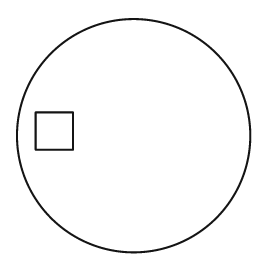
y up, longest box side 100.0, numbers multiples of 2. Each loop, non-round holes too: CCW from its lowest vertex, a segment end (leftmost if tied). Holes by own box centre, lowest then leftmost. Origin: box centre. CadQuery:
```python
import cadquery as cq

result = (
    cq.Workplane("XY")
    .moveTo(0.0, 0.0)
    .circle(50.0)
    .moveTo(-42.0, -6.0)
    .lineTo(-26.0, -6.0)
    .lineTo(-26.0, 10.0)
    .lineTo(-42.0, 10.0)
    .close()
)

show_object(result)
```